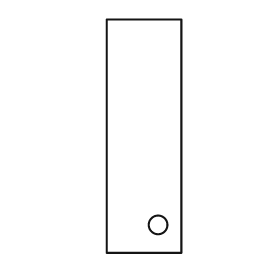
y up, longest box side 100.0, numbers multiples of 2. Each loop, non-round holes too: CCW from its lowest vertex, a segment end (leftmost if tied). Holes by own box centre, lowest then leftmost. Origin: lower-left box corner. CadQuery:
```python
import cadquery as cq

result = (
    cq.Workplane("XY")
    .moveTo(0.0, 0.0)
    .lineTo(32.0, 0.0)
    .lineTo(32.0, 100.0)
    .lineTo(0.0, 100.0)
    .close()
    .moveTo(22.0, 12.0)
    .circle(4.0)
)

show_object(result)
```